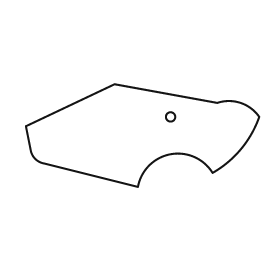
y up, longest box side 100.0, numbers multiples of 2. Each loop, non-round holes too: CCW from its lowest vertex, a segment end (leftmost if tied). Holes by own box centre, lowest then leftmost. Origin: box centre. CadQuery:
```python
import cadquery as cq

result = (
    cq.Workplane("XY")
    .moveTo(-2.0, -22.0)
    .threePointArc((12.0, -8.0), (30.0, -16.0))
    .threePointArc((42.0, -6.0), (50.0, 8.0))
    .threePointArc((42.0, 14.0), (32.0, 14.0))
    .lineTo(-12.0, 22.0)
    .lineTo(-50.0, 4.0)
    .lineTo(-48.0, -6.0)
    .threePointArc((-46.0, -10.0), (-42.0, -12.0))
    .close()
    .moveTo(12.0, 8.0)
    .circle(2.0)
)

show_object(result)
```